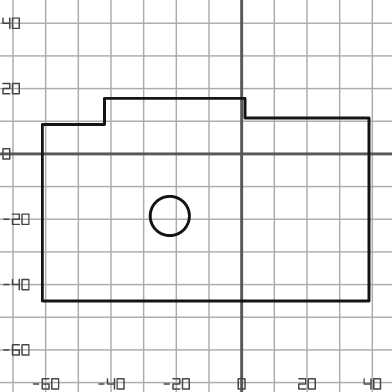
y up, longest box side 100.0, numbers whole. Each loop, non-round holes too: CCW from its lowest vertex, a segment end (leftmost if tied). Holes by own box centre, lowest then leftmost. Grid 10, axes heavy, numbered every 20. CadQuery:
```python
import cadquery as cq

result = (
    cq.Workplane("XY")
    .moveTo(-61.0, -45.0)
    .lineTo(39.0, -45.0)
    .lineTo(39.0, 11.0)
    .lineTo(1.0, 11.0)
    .lineTo(1.0, 17.0)
    .lineTo(-42.0, 17.0)
    .lineTo(-42.0, 9.0)
    .lineTo(-61.0, 9.0)
    .close()
    .moveTo(-22.0, -19.0)
    .circle(6.0)
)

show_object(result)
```